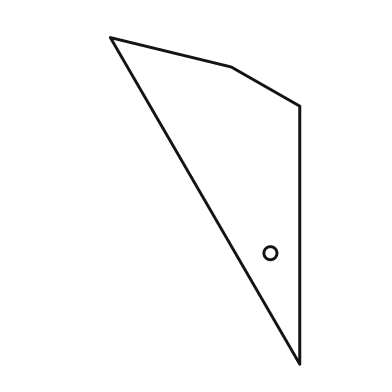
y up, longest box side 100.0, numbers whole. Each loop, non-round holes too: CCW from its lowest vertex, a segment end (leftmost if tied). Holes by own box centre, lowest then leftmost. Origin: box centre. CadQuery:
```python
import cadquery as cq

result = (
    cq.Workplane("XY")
    .moveTo(29.0, -50.0)
    .lineTo(29.0, 29.0)
    .lineTo(8.0, 41.0)
    .lineTo(-29.0, 50.0)
    .close()
    .moveTo(20.0, -16.0)
    .circle(2.0)
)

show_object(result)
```